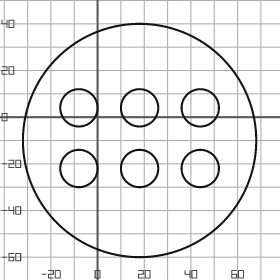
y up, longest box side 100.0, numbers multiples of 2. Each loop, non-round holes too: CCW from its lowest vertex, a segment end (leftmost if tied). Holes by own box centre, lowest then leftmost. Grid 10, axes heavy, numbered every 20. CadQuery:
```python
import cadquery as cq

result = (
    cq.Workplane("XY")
    .moveTo(18.0, -10.0)
    .circle(50.0)
    .moveTo(-8.0, -22.0)
    .circle(8.0)
    .moveTo(18.0, -22.0)
    .circle(8.0)
    .moveTo(44.0, -22.0)
    .circle(8.0)
    .moveTo(-8.0, 4.0)
    .circle(8.0)
    .moveTo(18.0, 4.0)
    .circle(8.0)
    .moveTo(44.0, 4.0)
    .circle(8.0)
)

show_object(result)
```